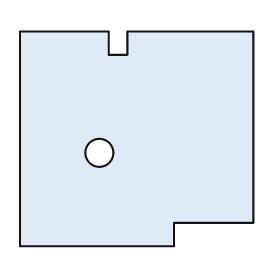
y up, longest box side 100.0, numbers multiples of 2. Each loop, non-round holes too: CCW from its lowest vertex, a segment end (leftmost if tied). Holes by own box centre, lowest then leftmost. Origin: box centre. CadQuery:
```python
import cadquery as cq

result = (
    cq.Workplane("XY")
    .moveTo(-50.0, -46.0)
    .lineTo(16.0, -46.0)
    .lineTo(16.0, -36.0)
    .lineTo(50.0, -36.0)
    .lineTo(50.0, 46.0)
    .lineTo(-4.0, 46.0)
    .lineTo(-4.0, 36.0)
    .lineTo(-12.0, 36.0)
    .lineTo(-12.0, 46.0)
    .lineTo(-50.0, 46.0)
    .close()
    .moveTo(-16.0, -6.0)
    .circle(6.0)
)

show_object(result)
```